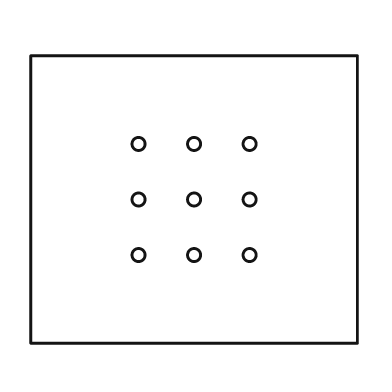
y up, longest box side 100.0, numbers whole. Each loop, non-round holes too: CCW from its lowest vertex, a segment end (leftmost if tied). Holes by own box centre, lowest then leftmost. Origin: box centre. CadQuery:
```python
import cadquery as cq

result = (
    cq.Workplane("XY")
    .moveTo(-50.0, -44.0)
    .lineTo(50.0, -44.0)
    .lineTo(50.0, 44.0)
    .lineTo(-50.0, 44.0)
    .close()
    .moveTo(-17.0, -17.0)
    .circle(2.0)
    .moveTo(0.0, -17.0)
    .circle(2.0)
    .moveTo(17.0, -17.0)
    .circle(2.0)
    .moveTo(-17.0, 0.0)
    .circle(2.0)
    .moveTo(0.0, 0.0)
    .circle(2.0)
    .moveTo(17.0, 0.0)
    .circle(2.0)
    .moveTo(-17.0, 17.0)
    .circle(2.0)
    .moveTo(0.0, 17.0)
    .circle(2.0)
    .moveTo(17.0, 17.0)
    .circle(2.0)
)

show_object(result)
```